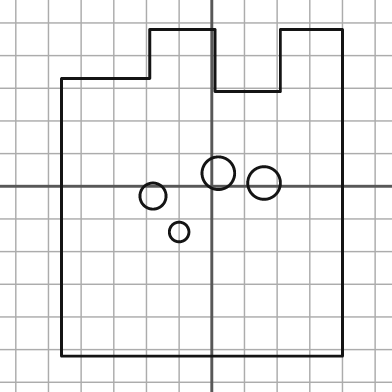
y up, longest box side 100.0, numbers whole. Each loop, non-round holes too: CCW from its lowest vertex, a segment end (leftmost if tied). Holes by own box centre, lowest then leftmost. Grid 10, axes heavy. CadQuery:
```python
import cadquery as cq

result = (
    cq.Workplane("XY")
    .moveTo(-46.0, -52.0)
    .lineTo(40.0, -52.0)
    .lineTo(40.0, 48.0)
    .lineTo(21.0, 48.0)
    .lineTo(21.0, 29.0)
    .lineTo(1.0, 29.0)
    .lineTo(1.0, 48.0)
    .lineTo(-19.0, 48.0)
    .lineTo(-19.0, 33.0)
    .lineTo(-46.0, 33.0)
    .close()
    .moveTo(-10.0, -14.0)
    .circle(3.0)
    .moveTo(-18.0, -3.0)
    .circle(4.0)
    .moveTo(16.0, 1.0)
    .circle(5.0)
    .moveTo(2.0, 4.0)
    .circle(5.0)
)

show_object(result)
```